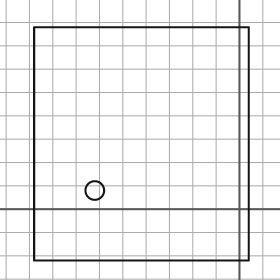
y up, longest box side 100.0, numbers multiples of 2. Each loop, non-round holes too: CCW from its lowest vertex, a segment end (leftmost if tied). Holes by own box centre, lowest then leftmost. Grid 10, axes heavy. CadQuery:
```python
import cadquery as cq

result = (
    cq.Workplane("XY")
    .moveTo(-88.0, -22.0)
    .lineTo(4.0, -22.0)
    .lineTo(4.0, 78.0)
    .lineTo(-88.0, 78.0)
    .close()
    .moveTo(-62.0, 8.0)
    .circle(4.0)
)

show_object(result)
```